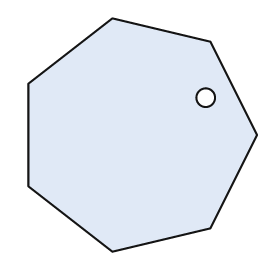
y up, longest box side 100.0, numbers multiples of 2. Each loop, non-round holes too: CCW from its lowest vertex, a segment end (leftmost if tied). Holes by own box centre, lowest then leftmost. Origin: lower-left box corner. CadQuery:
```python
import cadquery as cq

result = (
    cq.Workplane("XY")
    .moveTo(36.0, 0.0)
    .lineTo(78.0, 10.0)
    .lineTo(98.0, 50.0)
    .lineTo(78.0, 90.0)
    .lineTo(36.0, 100.0)
    .lineTo(0.0, 72.0)
    .lineTo(0.0, 28.0)
    .close()
    .moveTo(76.0, 66.0)
    .circle(4.0)
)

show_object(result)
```